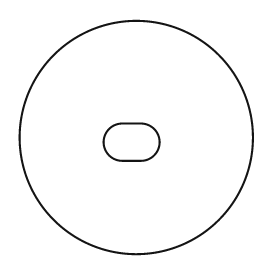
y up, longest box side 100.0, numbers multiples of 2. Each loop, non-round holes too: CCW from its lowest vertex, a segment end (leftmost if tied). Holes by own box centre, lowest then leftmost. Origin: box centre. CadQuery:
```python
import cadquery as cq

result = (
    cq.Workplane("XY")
    .moveTo(0.0, 0.0)
    .circle(50.0)
    .moveTo(-6.0, -10.0)
    .lineTo(2.0, -10.0)
    .threePointArc((10.0, -2.0), (2.0, 6.0))
    .lineTo(-6.0, 6.0)
    .threePointArc((-14.0, -2.0), (-6.0, -10.0))
    .close()
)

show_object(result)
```